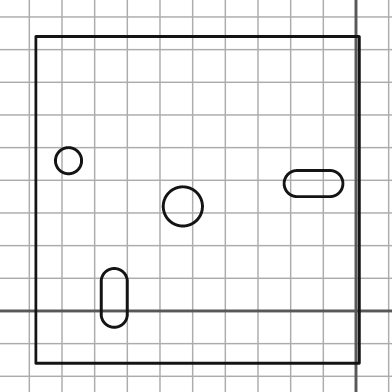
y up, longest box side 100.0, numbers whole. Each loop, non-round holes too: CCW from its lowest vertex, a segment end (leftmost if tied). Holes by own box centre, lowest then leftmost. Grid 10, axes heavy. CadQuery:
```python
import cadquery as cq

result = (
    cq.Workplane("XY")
    .moveTo(-98.0, -16.0)
    .lineTo(1.0, -16.0)
    .lineTo(1.0, 84.0)
    .lineTo(-98.0, 84.0)
    .close()
    .moveTo(-78.0, -1.0)
    .threePointArc((-74.0, -5.0), (-70.0, -1.0))
    .lineTo(-70.0, 9.0)
    .threePointArc((-74.0, 13.0), (-78.0, 9.0))
    .close()
    .moveTo(-53.0, 32.0)
    .circle(6.0)
    .moveTo(-18.0, 35.0)
    .lineTo(-8.0, 35.0)
    .threePointArc((-4.0, 39.0), (-8.0, 43.0))
    .lineTo(-18.0, 43.0)
    .threePointArc((-22.0, 39.0), (-18.0, 35.0))
    .close()
    .moveTo(-88.0, 46.0)
    .circle(4.0)
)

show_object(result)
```